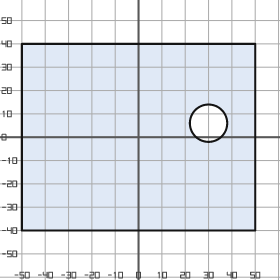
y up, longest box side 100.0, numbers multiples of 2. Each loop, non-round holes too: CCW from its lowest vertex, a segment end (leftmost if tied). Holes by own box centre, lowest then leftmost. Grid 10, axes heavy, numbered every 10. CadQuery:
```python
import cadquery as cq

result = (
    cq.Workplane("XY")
    .moveTo(-50.0, -40.0)
    .lineTo(50.0, -40.0)
    .lineTo(50.0, 40.0)
    .lineTo(-50.0, 40.0)
    .close()
    .moveTo(30.0, 6.0)
    .circle(8.0)
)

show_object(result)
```